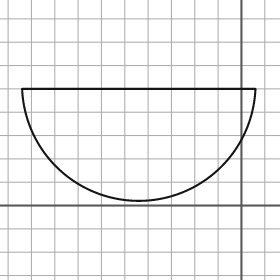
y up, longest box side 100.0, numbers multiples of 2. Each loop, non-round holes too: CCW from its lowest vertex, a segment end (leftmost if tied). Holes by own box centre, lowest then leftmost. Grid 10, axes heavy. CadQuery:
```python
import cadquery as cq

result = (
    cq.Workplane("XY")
    .moveTo(-94.0, 50.0)
    .threePointArc((-44.0, 2.0), (6.0, 50.0))
    .close()
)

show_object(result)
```